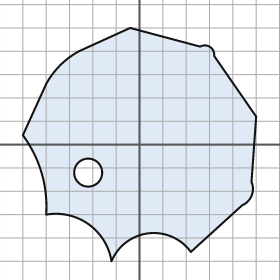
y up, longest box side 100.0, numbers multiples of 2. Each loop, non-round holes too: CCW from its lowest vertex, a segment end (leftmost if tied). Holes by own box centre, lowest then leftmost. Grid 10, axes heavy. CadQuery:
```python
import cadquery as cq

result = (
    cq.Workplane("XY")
    .moveTo(-12.0, -50.0)
    .threePointArc((4.0, -38.0), (22.0, -46.0))
    .lineTo(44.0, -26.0)
    .threePointArc((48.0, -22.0), (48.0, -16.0))
    .lineTo(50.0, 12.0)
    .lineTo(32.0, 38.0)
    .threePointArc((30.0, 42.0), (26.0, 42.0))
    .lineTo(-4.0, 50.0)
    .lineTo(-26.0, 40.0)
    .threePointArc((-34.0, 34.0), (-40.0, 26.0))
    .lineTo(-50.0, 4.0)
    .threePointArc((-42.0, -12.0), (-40.0, -30.0))
    .threePointArc((-22.0, -34.0), (-12.0, -50.0))
    .close()
    .moveTo(-22.0, -12.0)
    .circle(6.0)
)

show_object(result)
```